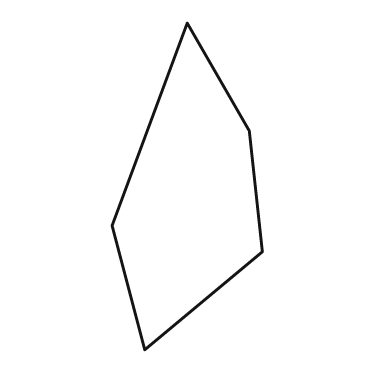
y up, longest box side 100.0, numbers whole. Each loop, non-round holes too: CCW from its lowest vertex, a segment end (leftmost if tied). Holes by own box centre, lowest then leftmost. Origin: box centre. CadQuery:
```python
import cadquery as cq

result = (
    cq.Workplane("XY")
    .moveTo(-13.0, -50.0)
    .lineTo(23.0, -20.0)
    .lineTo(19.0, 17.0)
    .lineTo(0.0, 50.0)
    .lineTo(-23.0, -12.0)
    .close()
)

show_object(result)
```